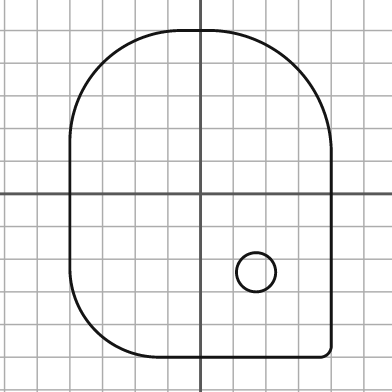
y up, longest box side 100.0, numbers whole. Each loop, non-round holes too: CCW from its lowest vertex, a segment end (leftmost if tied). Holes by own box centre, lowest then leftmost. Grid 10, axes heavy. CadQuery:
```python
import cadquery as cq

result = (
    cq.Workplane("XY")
    .moveTo(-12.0, -50.0)
    .lineTo(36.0, -50.0)
    .threePointArc((39.0, -49.0), (40.0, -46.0))
    .lineTo(40.0, 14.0)
    .threePointArc((29.0, 39.0), (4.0, 50.0))
    .lineTo(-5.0, 50.0)
    .threePointArc((-30.0, 40.0), (-40.0, 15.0))
    .lineTo(-40.0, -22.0)
    .threePointArc((-32.0, -42.0), (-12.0, -50.0))
    .close()
    .moveTo(17.0, -24.0)
    .circle(6.0)
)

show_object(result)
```